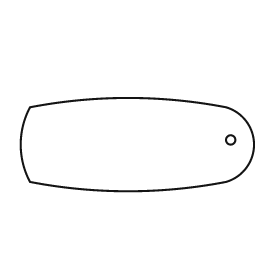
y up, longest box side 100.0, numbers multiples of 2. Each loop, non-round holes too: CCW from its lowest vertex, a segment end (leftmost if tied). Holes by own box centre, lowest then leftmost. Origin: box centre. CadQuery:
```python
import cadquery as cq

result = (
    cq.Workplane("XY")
    .moveTo(-46.0, -16.0)
    .threePointArc((-4.0, -20.0), (38.0, -16.0))
    .threePointArc((50.0, 0.0), (38.0, 16.0))
    .threePointArc((-4.0, 20.0), (-46.0, 16.0))
    .threePointArc((-50.0, 0.0), (-46.0, -16.0))
    .close()
    .moveTo(40.0, 2.0)
    .circle(2.0)
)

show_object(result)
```